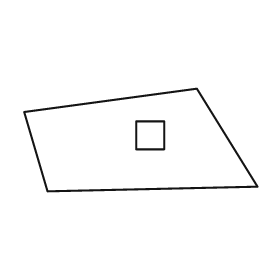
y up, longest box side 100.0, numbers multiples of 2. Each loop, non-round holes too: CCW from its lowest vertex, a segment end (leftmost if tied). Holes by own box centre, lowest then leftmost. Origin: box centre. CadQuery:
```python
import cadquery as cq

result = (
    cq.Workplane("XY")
    .moveTo(-40.0, -22.0)
    .lineTo(50.0, -20.0)
    .lineTo(24.0, 22.0)
    .lineTo(-50.0, 12.0)
    .close()
    .moveTo(-2.0, -4.0)
    .lineTo(10.0, -4.0)
    .lineTo(10.0, 8.0)
    .lineTo(-2.0, 8.0)
    .close()
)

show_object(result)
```